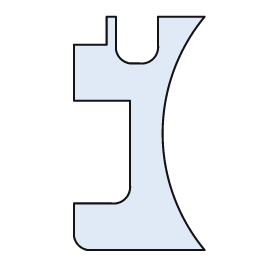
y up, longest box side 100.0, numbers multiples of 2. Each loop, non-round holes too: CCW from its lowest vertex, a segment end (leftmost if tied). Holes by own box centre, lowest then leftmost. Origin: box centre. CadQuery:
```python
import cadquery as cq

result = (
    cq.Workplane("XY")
    .moveTo(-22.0, -50.0)
    .lineTo(28.0, -50.0)
    .threePointArc((10.0, 0.0), (28.0, 50.0))
    .lineTo(8.0, 50.0)
    .lineTo(8.0, 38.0)
    .threePointArc((6.0, 32.0), (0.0, 30.0))
    .lineTo(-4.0, 30.0)
    .threePointArc((-8.0, 32.0), (-10.0, 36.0))
    .lineTo(-10.0, 50.0)
    .lineTo(-14.0, 50.0)
    .lineTo(-14.0, 38.0)
    .lineTo(-28.0, 38.0)
    .lineTo(-28.0, 14.0)
    .lineTo(-4.0, 14.0)
    .lineTo(-4.0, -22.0)
    .threePointArc((-6.0, -28.0), (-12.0, -30.0))
    .lineTo(-28.0, -30.0)
    .lineTo(-28.0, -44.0)
    .threePointArc((-26.0, -48.0), (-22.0, -50.0))
    .close()
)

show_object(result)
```